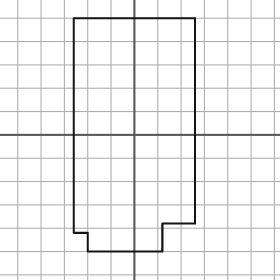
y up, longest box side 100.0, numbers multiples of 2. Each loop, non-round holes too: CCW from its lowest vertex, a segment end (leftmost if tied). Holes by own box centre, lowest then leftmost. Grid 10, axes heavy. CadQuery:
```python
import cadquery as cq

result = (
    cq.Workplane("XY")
    .moveTo(-20.0, -50.0)
    .lineTo(12.0, -50.0)
    .lineTo(12.0, -38.0)
    .lineTo(26.0, -38.0)
    .lineTo(26.0, 50.0)
    .lineTo(-26.0, 50.0)
    .lineTo(-26.0, -42.0)
    .lineTo(-20.0, -42.0)
    .close()
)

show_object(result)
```